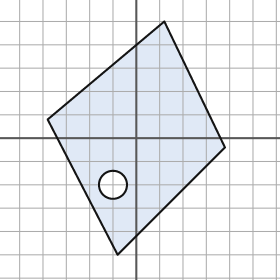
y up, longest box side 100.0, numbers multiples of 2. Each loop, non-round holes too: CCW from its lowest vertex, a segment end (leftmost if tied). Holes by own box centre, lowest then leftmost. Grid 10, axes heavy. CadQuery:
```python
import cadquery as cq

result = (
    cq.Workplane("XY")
    .moveTo(-8.0, -50.0)
    .lineTo(38.0, -4.0)
    .lineTo(12.0, 50.0)
    .lineTo(-38.0, 8.0)
    .close()
    .moveTo(-10.0, -20.0)
    .circle(6.0)
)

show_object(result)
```